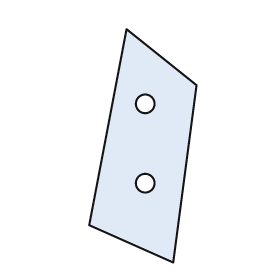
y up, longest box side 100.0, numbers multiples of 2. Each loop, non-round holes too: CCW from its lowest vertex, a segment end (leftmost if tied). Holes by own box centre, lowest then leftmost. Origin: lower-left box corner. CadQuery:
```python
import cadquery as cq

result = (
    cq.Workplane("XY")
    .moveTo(36.0, 0.0)
    .lineTo(46.0, 76.0)
    .lineTo(16.0, 100.0)
    .lineTo(0.0, 16.0)
    .close()
    .moveTo(24.0, 34.0)
    .circle(4.0)
    .moveTo(24.0, 68.0)
    .circle(4.0)
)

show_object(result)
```